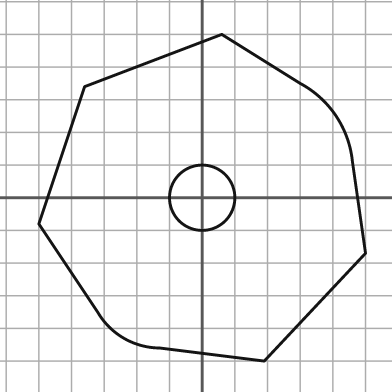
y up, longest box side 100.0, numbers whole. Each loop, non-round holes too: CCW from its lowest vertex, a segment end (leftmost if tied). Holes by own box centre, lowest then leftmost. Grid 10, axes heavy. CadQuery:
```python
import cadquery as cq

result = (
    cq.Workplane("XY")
    .moveTo(19.0, -50.0)
    .lineTo(50.0, -17.0)
    .lineTo(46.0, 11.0)
    .threePointArc((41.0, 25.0), (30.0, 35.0))
    .lineTo(6.0, 50.0)
    .lineTo(-36.0, 34.0)
    .lineTo(-50.0, -8.0)
    .lineTo(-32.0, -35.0)
    .threePointArc((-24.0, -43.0), (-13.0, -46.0))
    .close()
    .moveTo(0.0, 0.0)
    .circle(10.0)
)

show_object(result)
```